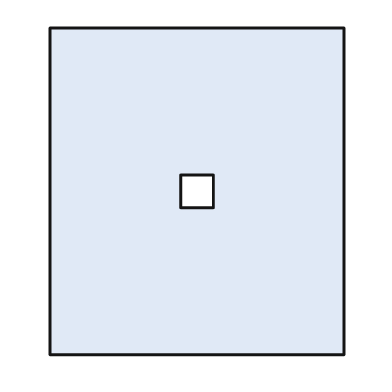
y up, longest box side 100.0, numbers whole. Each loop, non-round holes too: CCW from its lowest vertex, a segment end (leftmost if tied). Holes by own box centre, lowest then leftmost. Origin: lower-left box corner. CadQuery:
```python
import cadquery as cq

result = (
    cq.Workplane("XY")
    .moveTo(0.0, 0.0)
    .lineTo(90.0, 0.0)
    .lineTo(90.0, 100.0)
    .lineTo(0.0, 100.0)
    .close()
    .moveTo(40.0, 45.0)
    .lineTo(50.0, 45.0)
    .lineTo(50.0, 55.0)
    .lineTo(40.0, 55.0)
    .close()
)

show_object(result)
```